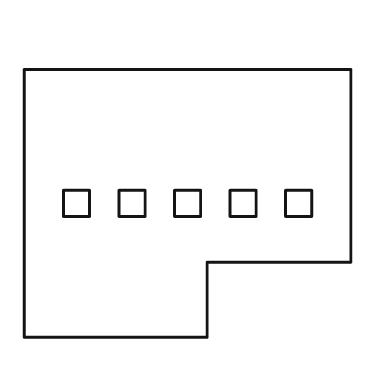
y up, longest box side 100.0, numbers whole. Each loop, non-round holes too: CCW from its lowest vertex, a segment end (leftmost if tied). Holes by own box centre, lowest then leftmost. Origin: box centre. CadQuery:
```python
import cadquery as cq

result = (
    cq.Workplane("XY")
    .moveTo(-50.0, -41.0)
    .lineTo(6.0, -41.0)
    .lineTo(6.0, -18.0)
    .lineTo(50.0, -18.0)
    .lineTo(50.0, 41.0)
    .lineTo(-50.0, 41.0)
    .close()
    .moveTo(-38.0, -4.0)
    .lineTo(-30.0, -4.0)
    .lineTo(-30.0, 4.0)
    .lineTo(-38.0, 4.0)
    .close()
    .moveTo(-21.0, -4.0)
    .lineTo(-13.0, -4.0)
    .lineTo(-13.0, 4.0)
    .lineTo(-21.0, 4.0)
    .close()
    .moveTo(-4.0, -4.0)
    .lineTo(4.0, -4.0)
    .lineTo(4.0, 4.0)
    .lineTo(-4.0, 4.0)
    .close()
    .moveTo(13.0, -4.0)
    .lineTo(21.0, -4.0)
    .lineTo(21.0, 4.0)
    .lineTo(13.0, 4.0)
    .close()
    .moveTo(30.0, -4.0)
    .lineTo(38.0, -4.0)
    .lineTo(38.0, 4.0)
    .lineTo(30.0, 4.0)
    .close()
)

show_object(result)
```